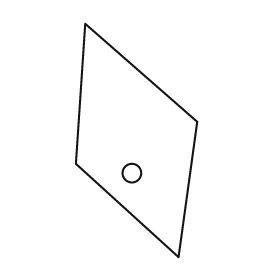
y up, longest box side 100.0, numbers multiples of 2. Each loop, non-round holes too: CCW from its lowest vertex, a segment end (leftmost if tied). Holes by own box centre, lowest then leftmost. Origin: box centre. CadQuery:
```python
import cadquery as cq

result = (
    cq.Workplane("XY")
    .moveTo(18.0, -50.0)
    .lineTo(26.0, 8.0)
    .lineTo(-22.0, 50.0)
    .lineTo(-26.0, -10.0)
    .close()
    .moveTo(-2.0, -14.0)
    .circle(4.0)
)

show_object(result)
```